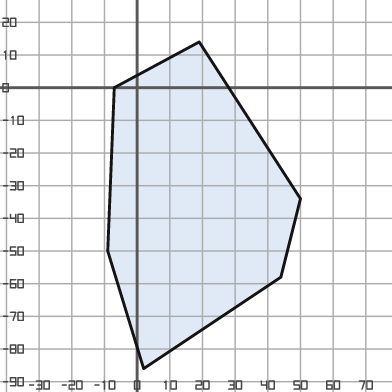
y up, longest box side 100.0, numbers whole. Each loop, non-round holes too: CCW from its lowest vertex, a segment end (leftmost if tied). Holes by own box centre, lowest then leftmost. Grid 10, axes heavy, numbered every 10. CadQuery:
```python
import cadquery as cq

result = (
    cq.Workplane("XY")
    .moveTo(2.0, -86.0)
    .lineTo(44.0, -58.0)
    .lineTo(50.0, -34.0)
    .lineTo(19.0, 14.0)
    .lineTo(-7.0, 0.0)
    .lineTo(-9.0, -50.0)
    .close()
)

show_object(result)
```